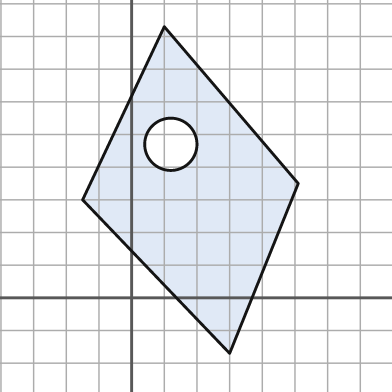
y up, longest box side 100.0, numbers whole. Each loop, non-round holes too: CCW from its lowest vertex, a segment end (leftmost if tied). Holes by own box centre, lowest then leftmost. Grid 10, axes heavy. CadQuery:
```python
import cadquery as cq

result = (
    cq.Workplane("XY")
    .moveTo(30.0, -17.0)
    .lineTo(51.0, 35.0)
    .lineTo(10.0, 83.0)
    .lineTo(-15.0, 30.0)
    .close()
    .moveTo(12.0, 47.0)
    .circle(8.0)
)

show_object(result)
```